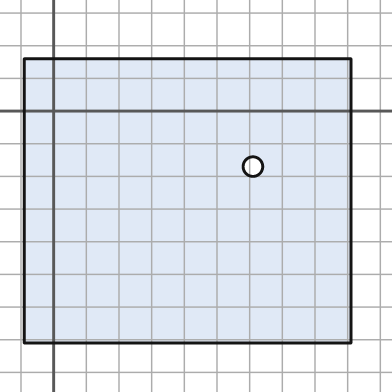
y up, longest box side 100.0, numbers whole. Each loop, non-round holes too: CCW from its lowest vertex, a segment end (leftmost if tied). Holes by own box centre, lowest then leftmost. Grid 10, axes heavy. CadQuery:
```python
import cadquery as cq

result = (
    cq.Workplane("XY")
    .moveTo(-9.0, -71.0)
    .lineTo(91.0, -71.0)
    .lineTo(91.0, 16.0)
    .lineTo(-9.0, 16.0)
    .close()
    .moveTo(61.0, -17.0)
    .circle(3.0)
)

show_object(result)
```